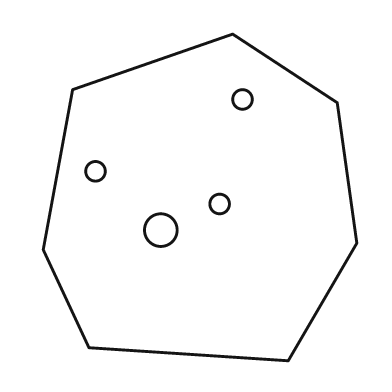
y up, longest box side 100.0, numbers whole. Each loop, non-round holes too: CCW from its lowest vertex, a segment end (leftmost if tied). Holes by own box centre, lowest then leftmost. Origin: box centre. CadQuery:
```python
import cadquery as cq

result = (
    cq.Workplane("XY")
    .moveTo(27.0, -50.0)
    .lineTo(48.0, -14.0)
    .lineTo(42.0, 29.0)
    .lineTo(10.0, 50.0)
    .lineTo(-39.0, 33.0)
    .lineTo(-48.0, -16.0)
    .lineTo(-34.0, -46.0)
    .close()
    .moveTo(-12.0, -10.0)
    .circle(5.0)
    .moveTo(6.0, -2.0)
    .circle(3.0)
    .moveTo(-32.0, 8.0)
    .circle(3.0)
    .moveTo(13.0, 30.0)
    .circle(3.0)
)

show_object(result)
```